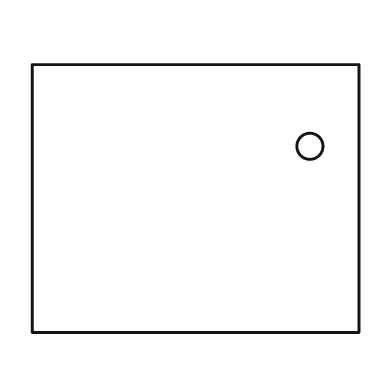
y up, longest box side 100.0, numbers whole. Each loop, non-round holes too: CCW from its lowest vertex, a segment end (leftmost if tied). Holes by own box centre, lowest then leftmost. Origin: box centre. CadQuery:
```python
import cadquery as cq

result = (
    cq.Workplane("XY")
    .moveTo(-50.0, -41.0)
    .lineTo(50.0, -41.0)
    .lineTo(50.0, 41.0)
    .lineTo(-50.0, 41.0)
    .close()
    .moveTo(35.0, 16.0)
    .circle(4.0)
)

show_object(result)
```